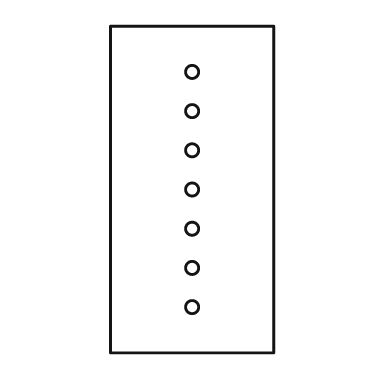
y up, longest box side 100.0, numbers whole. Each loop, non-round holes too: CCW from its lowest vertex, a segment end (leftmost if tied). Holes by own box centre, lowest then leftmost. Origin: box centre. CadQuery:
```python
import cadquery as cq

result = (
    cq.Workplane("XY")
    .moveTo(-25.0, -50.0)
    .lineTo(25.0, -50.0)
    .lineTo(25.0, 50.0)
    .lineTo(-25.0, 50.0)
    .close()
    .moveTo(0.0, -36.0)
    .circle(2.0)
    .moveTo(0.0, -24.0)
    .circle(2.0)
    .moveTo(0.0, -12.0)
    .circle(2.0)
    .moveTo(0.0, 0.0)
    .circle(2.0)
    .moveTo(0.0, 12.0)
    .circle(2.0)
    .moveTo(0.0, 24.0)
    .circle(2.0)
    .moveTo(0.0, 36.0)
    .circle(2.0)
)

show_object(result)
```